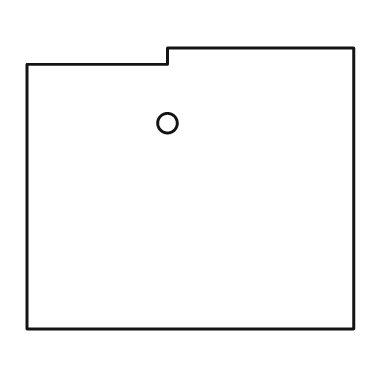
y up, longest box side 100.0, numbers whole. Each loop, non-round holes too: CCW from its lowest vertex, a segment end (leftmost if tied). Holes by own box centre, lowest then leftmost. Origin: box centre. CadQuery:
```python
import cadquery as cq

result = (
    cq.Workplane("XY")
    .moveTo(-50.0, -43.0)
    .lineTo(50.0, -43.0)
    .lineTo(50.0, 43.0)
    .lineTo(-7.0, 43.0)
    .lineTo(-7.0, 38.0)
    .lineTo(-50.0, 38.0)
    .close()
    .moveTo(-7.0, 20.0)
    .circle(3.0)
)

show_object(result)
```